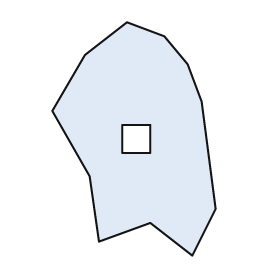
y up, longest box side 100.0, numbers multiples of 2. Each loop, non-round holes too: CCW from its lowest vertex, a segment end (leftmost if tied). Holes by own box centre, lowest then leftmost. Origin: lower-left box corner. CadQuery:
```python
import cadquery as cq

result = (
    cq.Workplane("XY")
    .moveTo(60.0, 0.0)
    .lineTo(70.0, 20.0)
    .lineTo(64.0, 66.0)
    .lineTo(58.0, 82.0)
    .lineTo(48.0, 94.0)
    .lineTo(32.0, 100.0)
    .lineTo(14.0, 86.0)
    .lineTo(0.0, 62.0)
    .lineTo(16.0, 34.0)
    .lineTo(20.0, 6.0)
    .lineTo(42.0, 14.0)
    .close()
    .moveTo(30.0, 44.0)
    .lineTo(42.0, 44.0)
    .lineTo(42.0, 56.0)
    .lineTo(30.0, 56.0)
    .close()
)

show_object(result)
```